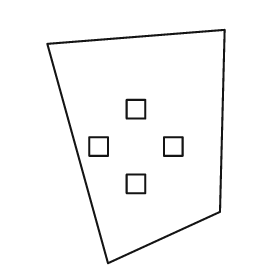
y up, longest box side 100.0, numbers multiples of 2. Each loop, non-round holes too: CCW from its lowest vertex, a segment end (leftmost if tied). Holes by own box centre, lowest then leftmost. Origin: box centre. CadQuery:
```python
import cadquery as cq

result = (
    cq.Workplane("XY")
    .moveTo(-12.0, -50.0)
    .lineTo(36.0, -28.0)
    .lineTo(38.0, 50.0)
    .lineTo(-38.0, 44.0)
    .close()
    .moveTo(-4.0, -20.0)
    .lineTo(4.0, -20.0)
    .lineTo(4.0, -12.0)
    .lineTo(-4.0, -12.0)
    .close()
    .moveTo(-20.0, -4.0)
    .lineTo(-12.0, -4.0)
    .lineTo(-12.0, 4.0)
    .lineTo(-20.0, 4.0)
    .close()
    .moveTo(12.0, -4.0)
    .lineTo(20.0, -4.0)
    .lineTo(20.0, 4.0)
    .lineTo(12.0, 4.0)
    .close()
    .moveTo(-4.0, 12.0)
    .lineTo(4.0, 12.0)
    .lineTo(4.0, 20.0)
    .lineTo(-4.0, 20.0)
    .close()
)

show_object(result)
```